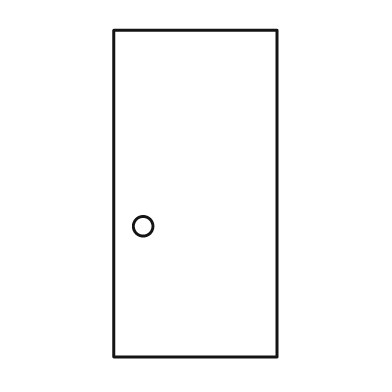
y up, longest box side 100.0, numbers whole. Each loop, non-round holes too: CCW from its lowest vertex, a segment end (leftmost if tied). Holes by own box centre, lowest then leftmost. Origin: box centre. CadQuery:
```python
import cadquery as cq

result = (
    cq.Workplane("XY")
    .moveTo(-25.0, -50.0)
    .lineTo(25.0, -50.0)
    .lineTo(25.0, 50.0)
    .lineTo(-25.0, 50.0)
    .close()
    .moveTo(-16.0, -10.0)
    .circle(3.0)
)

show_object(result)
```